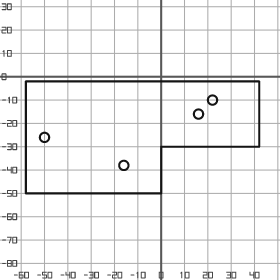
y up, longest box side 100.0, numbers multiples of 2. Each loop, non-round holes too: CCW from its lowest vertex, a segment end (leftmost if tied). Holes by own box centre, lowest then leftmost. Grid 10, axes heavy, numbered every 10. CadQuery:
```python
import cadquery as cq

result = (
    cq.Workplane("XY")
    .moveTo(-58.0, -50.0)
    .lineTo(0.0, -50.0)
    .lineTo(0.0, -30.0)
    .lineTo(42.0, -30.0)
    .lineTo(42.0, -2.0)
    .lineTo(-58.0, -2.0)
    .close()
    .moveTo(-16.0, -38.0)
    .circle(2.0)
    .moveTo(-50.0, -26.0)
    .circle(2.0)
    .moveTo(16.0, -16.0)
    .circle(2.0)
    .moveTo(22.0, -10.0)
    .circle(2.0)
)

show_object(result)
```